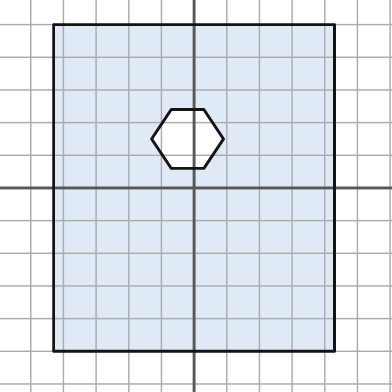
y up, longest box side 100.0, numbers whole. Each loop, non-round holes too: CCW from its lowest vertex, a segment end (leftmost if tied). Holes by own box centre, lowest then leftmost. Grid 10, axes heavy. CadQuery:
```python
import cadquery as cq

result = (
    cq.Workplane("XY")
    .moveTo(-43.0, -50.0)
    .lineTo(43.0, -50.0)
    .lineTo(43.0, 50.0)
    .lineTo(-43.0, 50.0)
    .close()
    .moveTo(-7.0, 6.0)
    .lineTo(3.0, 6.0)
    .lineTo(9.0, 15.0)
    .lineTo(3.0, 24.0)
    .lineTo(-7.0, 24.0)
    .lineTo(-13.0, 15.0)
    .close()
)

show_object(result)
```